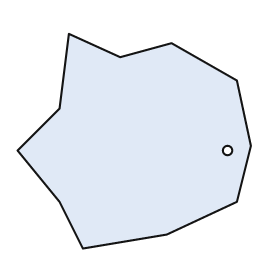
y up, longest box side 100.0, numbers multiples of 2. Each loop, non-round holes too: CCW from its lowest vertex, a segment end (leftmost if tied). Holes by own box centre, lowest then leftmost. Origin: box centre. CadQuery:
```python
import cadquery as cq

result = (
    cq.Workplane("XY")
    .moveTo(-22.0, -46.0)
    .lineTo(14.0, -40.0)
    .lineTo(44.0, -26.0)
    .lineTo(50.0, -2.0)
    .lineTo(44.0, 26.0)
    .lineTo(16.0, 42.0)
    .lineTo(-6.0, 36.0)
    .lineTo(-28.0, 46.0)
    .lineTo(-32.0, 14.0)
    .lineTo(-50.0, -4.0)
    .lineTo(-32.0, -26.0)
    .close()
    .moveTo(40.0, -4.0)
    .circle(2.0)
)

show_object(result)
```